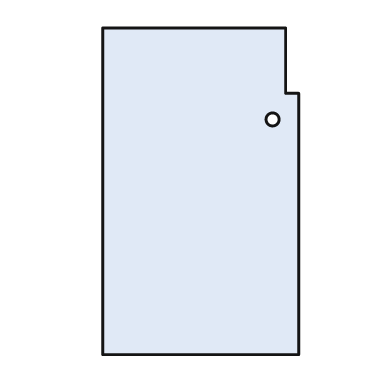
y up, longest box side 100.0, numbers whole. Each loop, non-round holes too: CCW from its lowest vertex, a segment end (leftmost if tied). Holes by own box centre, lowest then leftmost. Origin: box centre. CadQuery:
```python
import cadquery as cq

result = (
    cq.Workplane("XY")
    .moveTo(-30.0, -50.0)
    .lineTo(30.0, -50.0)
    .lineTo(30.0, 30.0)
    .lineTo(26.0, 30.0)
    .lineTo(26.0, 50.0)
    .lineTo(-30.0, 50.0)
    .close()
    .moveTo(22.0, 22.0)
    .circle(2.0)
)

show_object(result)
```